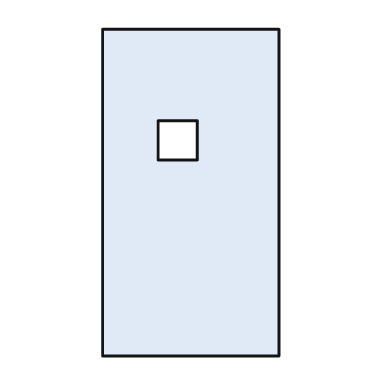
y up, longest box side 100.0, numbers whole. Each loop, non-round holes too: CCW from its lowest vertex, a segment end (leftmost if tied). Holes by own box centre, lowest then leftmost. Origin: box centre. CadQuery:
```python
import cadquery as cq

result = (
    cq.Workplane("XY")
    .moveTo(-27.0, -50.0)
    .lineTo(27.0, -50.0)
    .lineTo(27.0, 50.0)
    .lineTo(-27.0, 50.0)
    .close()
    .moveTo(-10.0, 10.0)
    .lineTo(2.0, 10.0)
    .lineTo(2.0, 22.0)
    .lineTo(-10.0, 22.0)
    .close()
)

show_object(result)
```